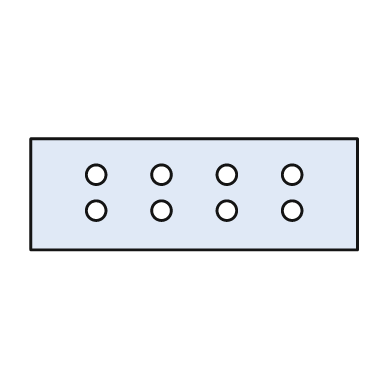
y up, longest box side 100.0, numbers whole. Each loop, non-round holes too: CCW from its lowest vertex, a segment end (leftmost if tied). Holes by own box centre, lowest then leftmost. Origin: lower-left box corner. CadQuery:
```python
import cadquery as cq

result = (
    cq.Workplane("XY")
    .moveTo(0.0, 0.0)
    .lineTo(100.0, 0.0)
    .lineTo(100.0, 34.0)
    .lineTo(0.0, 34.0)
    .close()
    .moveTo(20.0, 12.0)
    .circle(3.0)
    .moveTo(40.0, 12.0)
    .circle(3.0)
    .moveTo(60.0, 12.0)
    .circle(3.0)
    .moveTo(80.0, 12.0)
    .circle(3.0)
    .moveTo(20.0, 23.0)
    .circle(3.0)
    .moveTo(40.0, 23.0)
    .circle(3.0)
    .moveTo(60.0, 23.0)
    .circle(3.0)
    .moveTo(80.0, 23.0)
    .circle(3.0)
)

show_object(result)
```